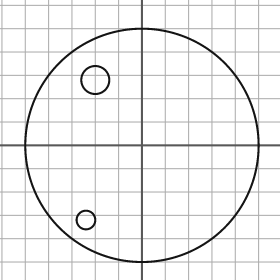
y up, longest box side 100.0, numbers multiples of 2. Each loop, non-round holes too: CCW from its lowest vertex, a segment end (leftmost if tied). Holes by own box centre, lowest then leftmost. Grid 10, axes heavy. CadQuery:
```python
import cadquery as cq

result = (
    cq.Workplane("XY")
    .moveTo(0.0, 0.0)
    .circle(50.0)
    .moveTo(-24.0, -32.0)
    .circle(4.0)
    .moveTo(-20.0, 28.0)
    .circle(6.0)
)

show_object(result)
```